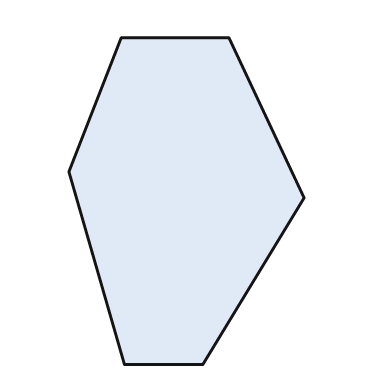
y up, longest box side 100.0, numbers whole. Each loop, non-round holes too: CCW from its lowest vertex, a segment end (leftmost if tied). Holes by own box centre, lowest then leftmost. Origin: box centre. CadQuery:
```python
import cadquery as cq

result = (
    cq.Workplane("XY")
    .moveTo(-19.0, -50.0)
    .lineTo(5.0, -50.0)
    .lineTo(36.0, 1.0)
    .lineTo(13.0, 50.0)
    .lineTo(-20.0, 50.0)
    .lineTo(-36.0, 9.0)
    .close()
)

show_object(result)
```